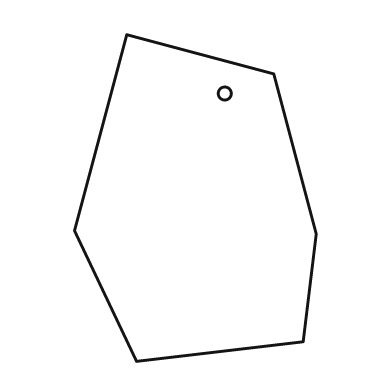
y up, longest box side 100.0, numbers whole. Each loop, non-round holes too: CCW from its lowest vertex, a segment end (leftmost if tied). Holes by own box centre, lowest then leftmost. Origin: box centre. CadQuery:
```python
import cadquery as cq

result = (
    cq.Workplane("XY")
    .moveTo(-18.0, -50.0)
    .lineTo(33.0, -44.0)
    .lineTo(37.0, -11.0)
    .lineTo(24.0, 38.0)
    .lineTo(-21.0, 50.0)
    .lineTo(-37.0, -10.0)
    .close()
    .moveTo(9.0, 32.0)
    .circle(2.0)
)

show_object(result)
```